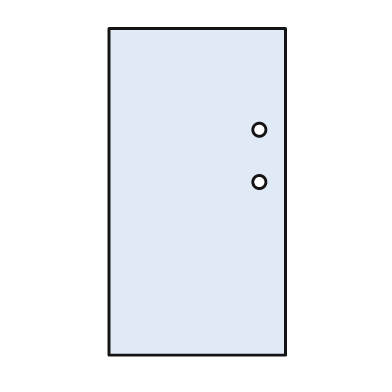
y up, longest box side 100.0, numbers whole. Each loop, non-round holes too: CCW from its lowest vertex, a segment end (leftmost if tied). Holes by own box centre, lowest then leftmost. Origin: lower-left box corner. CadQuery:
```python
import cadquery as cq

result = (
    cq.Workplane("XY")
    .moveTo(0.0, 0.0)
    .lineTo(54.0, 0.0)
    .lineTo(54.0, 100.0)
    .lineTo(0.0, 100.0)
    .close()
    .moveTo(46.0, 53.0)
    .circle(2.0)
    .moveTo(46.0, 69.0)
    .circle(2.0)
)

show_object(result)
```